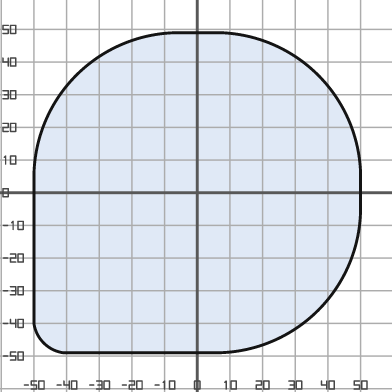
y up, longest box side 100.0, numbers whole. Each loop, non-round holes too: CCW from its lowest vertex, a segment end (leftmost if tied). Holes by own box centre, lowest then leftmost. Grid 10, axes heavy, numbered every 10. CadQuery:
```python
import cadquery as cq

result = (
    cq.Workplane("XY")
    .moveTo(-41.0, -49.0)
    .lineTo(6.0, -49.0)
    .threePointArc((37.0, -36.0), (50.0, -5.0))
    .lineTo(50.0, 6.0)
    .threePointArc((37.0, 36.0), (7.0, 49.0))
    .lineTo(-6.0, 49.0)
    .threePointArc((-37.0, 36.0), (-50.0, 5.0))
    .lineTo(-50.0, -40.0)
    .threePointArc((-47.0, -46.0), (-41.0, -49.0))
    .close()
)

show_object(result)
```